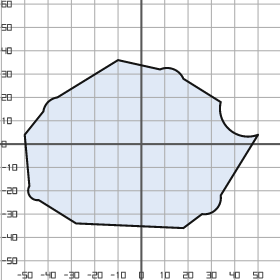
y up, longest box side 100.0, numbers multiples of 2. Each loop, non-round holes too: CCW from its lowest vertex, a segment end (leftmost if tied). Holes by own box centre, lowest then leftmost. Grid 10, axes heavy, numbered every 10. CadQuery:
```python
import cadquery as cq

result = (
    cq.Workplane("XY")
    .moveTo(18.0, -36.0)
    .lineTo(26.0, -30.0)
    .threePointArc((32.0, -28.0), (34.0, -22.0))
    .lineTo(50.0, 4.0)
    .threePointArc((38.0, 6.0), (34.0, 18.0))
    .lineTo(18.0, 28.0)
    .threePointArc((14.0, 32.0), (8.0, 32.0))
    .lineTo(-10.0, 36.0)
    .lineTo(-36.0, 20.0)
    .threePointArc((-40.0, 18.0), (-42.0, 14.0))
    .lineTo(-50.0, 4.0)
    .lineTo(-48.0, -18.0)
    .threePointArc((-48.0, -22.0), (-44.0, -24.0))
    .lineTo(-28.0, -34.0)
    .close()
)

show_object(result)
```